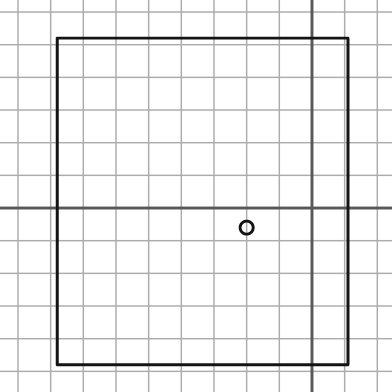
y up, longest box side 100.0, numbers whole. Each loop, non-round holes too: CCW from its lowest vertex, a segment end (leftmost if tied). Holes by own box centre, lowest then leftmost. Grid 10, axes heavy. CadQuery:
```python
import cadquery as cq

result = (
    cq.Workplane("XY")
    .moveTo(-78.0, -48.0)
    .lineTo(11.0, -48.0)
    .lineTo(11.0, 52.0)
    .lineTo(-78.0, 52.0)
    .close()
    .moveTo(-20.0, -6.0)
    .circle(2.0)
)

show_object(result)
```